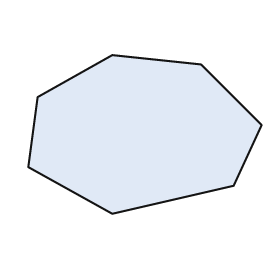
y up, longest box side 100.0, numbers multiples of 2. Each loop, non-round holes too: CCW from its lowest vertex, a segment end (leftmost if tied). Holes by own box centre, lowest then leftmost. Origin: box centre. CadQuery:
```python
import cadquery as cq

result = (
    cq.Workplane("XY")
    .moveTo(-14.0, -34.0)
    .lineTo(38.0, -22.0)
    .lineTo(50.0, 4.0)
    .lineTo(24.0, 30.0)
    .lineTo(-14.0, 34.0)
    .lineTo(-46.0, 16.0)
    .lineTo(-50.0, -14.0)
    .close()
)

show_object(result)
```